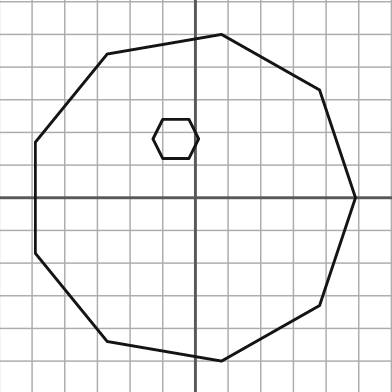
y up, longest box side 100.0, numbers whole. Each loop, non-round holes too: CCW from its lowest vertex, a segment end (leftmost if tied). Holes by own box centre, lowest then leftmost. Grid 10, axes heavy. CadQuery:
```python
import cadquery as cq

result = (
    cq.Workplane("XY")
    .moveTo(8.0, -50.0)
    .lineTo(38.0, -33.0)
    .lineTo(49.0, 0.0)
    .lineTo(38.0, 33.0)
    .lineTo(8.0, 50.0)
    .lineTo(-27.0, 44.0)
    .lineTo(-49.0, 17.0)
    .lineTo(-49.0, -17.0)
    .lineTo(-27.0, -44.0)
    .close()
    .moveTo(-10.0, 12.0)
    .lineTo(-2.0, 12.0)
    .lineTo(1.0, 18.0)
    .lineTo(-2.0, 24.0)
    .lineTo(-10.0, 24.0)
    .lineTo(-13.0, 18.0)
    .close()
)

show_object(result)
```